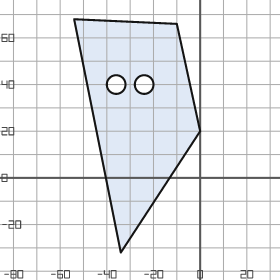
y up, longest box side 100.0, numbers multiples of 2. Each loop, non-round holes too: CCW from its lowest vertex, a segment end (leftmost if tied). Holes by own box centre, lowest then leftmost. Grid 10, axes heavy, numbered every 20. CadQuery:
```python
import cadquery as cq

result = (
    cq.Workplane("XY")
    .moveTo(-34.0, -32.0)
    .lineTo(0.0, 20.0)
    .lineTo(-10.0, 66.0)
    .lineTo(-54.0, 68.0)
    .close()
    .moveTo(-36.0, 40.0)
    .circle(4.0)
    .moveTo(-24.0, 40.0)
    .circle(4.0)
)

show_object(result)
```